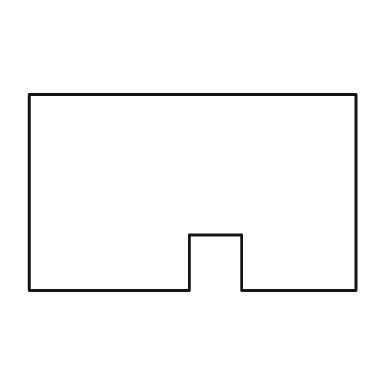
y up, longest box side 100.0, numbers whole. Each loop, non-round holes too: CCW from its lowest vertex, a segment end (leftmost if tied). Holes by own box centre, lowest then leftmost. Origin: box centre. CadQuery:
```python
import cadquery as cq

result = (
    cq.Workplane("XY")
    .moveTo(-50.0, -30.0)
    .lineTo(-1.0, -30.0)
    .lineTo(-1.0, -13.0)
    .lineTo(15.0, -13.0)
    .lineTo(15.0, -30.0)
    .lineTo(50.0, -30.0)
    .lineTo(50.0, 30.0)
    .lineTo(-50.0, 30.0)
    .close()
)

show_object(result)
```